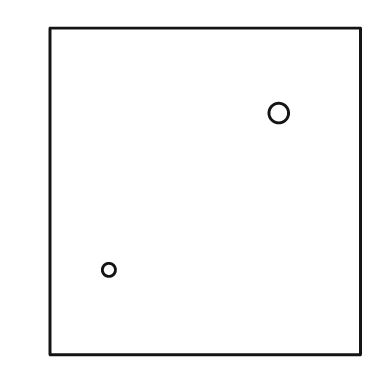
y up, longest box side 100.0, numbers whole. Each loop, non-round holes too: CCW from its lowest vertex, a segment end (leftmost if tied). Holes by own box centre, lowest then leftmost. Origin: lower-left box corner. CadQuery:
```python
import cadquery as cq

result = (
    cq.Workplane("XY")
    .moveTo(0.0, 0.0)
    .lineTo(95.0, 0.0)
    .lineTo(95.0, 100.0)
    .lineTo(0.0, 100.0)
    .close()
    .moveTo(18.0, 26.0)
    .circle(2.0)
    .moveTo(70.0, 74.0)
    .circle(3.0)
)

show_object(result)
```